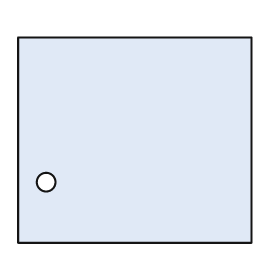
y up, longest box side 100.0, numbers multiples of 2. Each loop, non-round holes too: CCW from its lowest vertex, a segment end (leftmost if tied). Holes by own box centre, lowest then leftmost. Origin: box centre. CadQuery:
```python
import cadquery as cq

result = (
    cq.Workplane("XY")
    .moveTo(-50.0, -44.0)
    .lineTo(50.0, -44.0)
    .lineTo(50.0, 44.0)
    .lineTo(-50.0, 44.0)
    .close()
    .moveTo(-38.0, -18.0)
    .circle(4.0)
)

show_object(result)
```